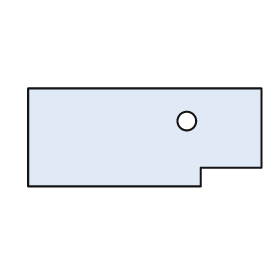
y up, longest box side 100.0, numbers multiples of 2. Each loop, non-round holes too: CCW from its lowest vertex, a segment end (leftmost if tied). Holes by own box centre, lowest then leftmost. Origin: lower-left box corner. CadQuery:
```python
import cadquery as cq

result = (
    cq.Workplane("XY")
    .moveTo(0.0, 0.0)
    .lineTo(74.0, 0.0)
    .lineTo(74.0, 8.0)
    .lineTo(100.0, 8.0)
    .lineTo(100.0, 42.0)
    .lineTo(0.0, 42.0)
    .close()
    .moveTo(68.0, 28.0)
    .circle(4.0)
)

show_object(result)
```